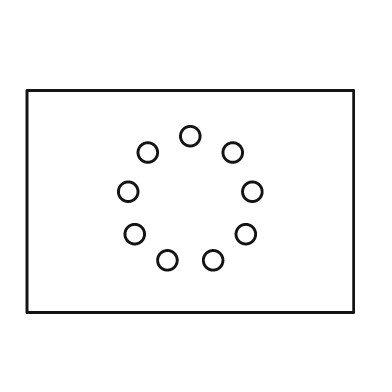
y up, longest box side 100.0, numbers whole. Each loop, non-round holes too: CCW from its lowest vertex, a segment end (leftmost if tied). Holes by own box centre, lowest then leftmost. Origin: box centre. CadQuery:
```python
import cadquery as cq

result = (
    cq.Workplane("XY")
    .moveTo(-50.0, -34.0)
    .lineTo(50.0, -34.0)
    .lineTo(50.0, 34.0)
    .lineTo(-50.0, 34.0)
    .close()
    .moveTo(-7.0, -18.0)
    .circle(3.0)
    .moveTo(7.0, -18.0)
    .circle(3.0)
    .moveTo(-17.0, -10.0)
    .circle(3.0)
    .moveTo(17.0, -10.0)
    .circle(3.0)
    .moveTo(-19.0, 3.0)
    .circle(3.0)
    .moveTo(19.0, 3.0)
    .circle(3.0)
    .moveTo(-13.0, 15.0)
    .circle(3.0)
    .moveTo(13.0, 15.0)
    .circle(3.0)
    .moveTo(0.0, 20.0)
    .circle(3.0)
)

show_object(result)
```